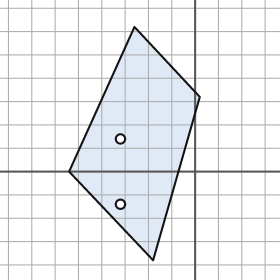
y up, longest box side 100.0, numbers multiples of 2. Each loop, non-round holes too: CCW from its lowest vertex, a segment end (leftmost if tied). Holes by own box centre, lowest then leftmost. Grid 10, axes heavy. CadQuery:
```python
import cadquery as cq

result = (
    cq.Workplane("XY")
    .moveTo(-18.0, -38.0)
    .lineTo(2.0, 32.0)
    .lineTo(-26.0, 62.0)
    .lineTo(-54.0, 0.0)
    .close()
    .moveTo(-32.0, -14.0)
    .circle(2.0)
    .moveTo(-32.0, 14.0)
    .circle(2.0)
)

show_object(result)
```